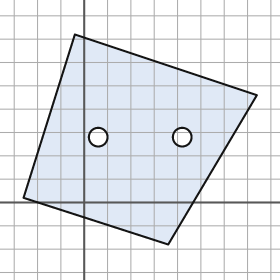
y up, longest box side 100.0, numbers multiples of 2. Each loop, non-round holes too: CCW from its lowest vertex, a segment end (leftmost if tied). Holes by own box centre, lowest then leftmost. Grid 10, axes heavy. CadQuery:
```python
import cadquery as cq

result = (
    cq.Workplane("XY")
    .moveTo(36.0, -18.0)
    .lineTo(74.0, 46.0)
    .lineTo(-4.0, 72.0)
    .lineTo(-26.0, 2.0)
    .close()
    .moveTo(6.0, 28.0)
    .circle(4.0)
    .moveTo(42.0, 28.0)
    .circle(4.0)
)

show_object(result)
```